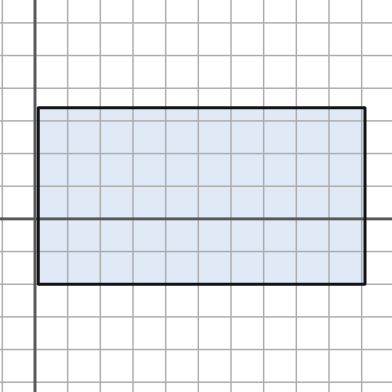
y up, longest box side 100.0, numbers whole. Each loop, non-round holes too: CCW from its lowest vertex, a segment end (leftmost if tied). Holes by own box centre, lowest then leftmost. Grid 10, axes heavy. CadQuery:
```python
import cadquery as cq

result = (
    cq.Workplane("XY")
    .moveTo(1.0, -20.0)
    .lineTo(101.0, -20.0)
    .lineTo(101.0, 34.0)
    .lineTo(1.0, 34.0)
    .close()
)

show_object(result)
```